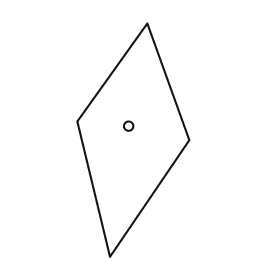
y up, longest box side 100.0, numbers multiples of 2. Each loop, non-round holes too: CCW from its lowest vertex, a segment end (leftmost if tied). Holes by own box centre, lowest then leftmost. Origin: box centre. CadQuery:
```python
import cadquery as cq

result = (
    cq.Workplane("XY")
    .moveTo(-10.0, -50.0)
    .lineTo(24.0, 0.0)
    .lineTo(6.0, 50.0)
    .lineTo(-24.0, 8.0)
    .close()
    .moveTo(-2.0, 6.0)
    .circle(2.0)
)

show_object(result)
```